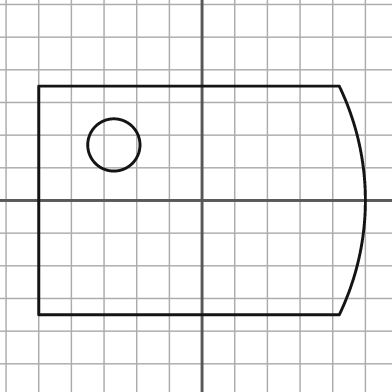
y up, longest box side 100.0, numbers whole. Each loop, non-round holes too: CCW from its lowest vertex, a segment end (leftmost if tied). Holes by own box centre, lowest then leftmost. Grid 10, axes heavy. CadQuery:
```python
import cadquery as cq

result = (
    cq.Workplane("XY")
    .moveTo(-50.0, -35.0)
    .lineTo(42.0, -35.0)
    .threePointArc((50.0, 0.0), (42.0, 35.0))
    .lineTo(-50.0, 35.0)
    .close()
    .moveTo(-27.0, 17.0)
    .circle(8.0)
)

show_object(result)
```